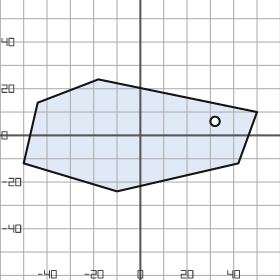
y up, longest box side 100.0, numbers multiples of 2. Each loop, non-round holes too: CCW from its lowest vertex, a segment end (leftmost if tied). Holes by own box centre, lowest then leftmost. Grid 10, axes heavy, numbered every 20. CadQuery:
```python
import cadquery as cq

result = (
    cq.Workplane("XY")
    .moveTo(-10.0, -24.0)
    .lineTo(42.0, -12.0)
    .lineTo(50.0, 10.0)
    .lineTo(-18.0, 24.0)
    .lineTo(-44.0, 14.0)
    .lineTo(-50.0, -12.0)
    .close()
    .moveTo(32.0, 6.0)
    .circle(2.0)
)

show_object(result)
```